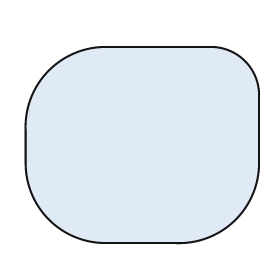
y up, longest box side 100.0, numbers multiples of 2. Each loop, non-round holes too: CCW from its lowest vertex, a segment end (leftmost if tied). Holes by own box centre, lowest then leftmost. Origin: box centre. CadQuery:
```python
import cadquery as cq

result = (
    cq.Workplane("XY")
    .moveTo(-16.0, -42.0)
    .lineTo(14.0, -42.0)
    .threePointArc((40.0, -32.0), (50.0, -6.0))
    .lineTo(50.0, 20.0)
    .threePointArc((44.0, 36.0), (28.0, 42.0))
    .lineTo(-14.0, 42.0)
    .threePointArc((-40.0, 32.0), (-50.0, 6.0))
    .lineTo(-50.0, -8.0)
    .threePointArc((-40.0, -32.0), (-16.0, -42.0))
    .close()
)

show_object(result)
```